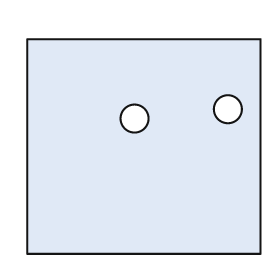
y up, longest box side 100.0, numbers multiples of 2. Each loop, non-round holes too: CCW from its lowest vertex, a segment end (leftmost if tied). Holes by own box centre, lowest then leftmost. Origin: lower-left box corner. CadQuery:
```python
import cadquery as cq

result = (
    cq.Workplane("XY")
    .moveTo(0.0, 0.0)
    .lineTo(100.0, 0.0)
    .lineTo(100.0, 92.0)
    .lineTo(0.0, 92.0)
    .close()
    .moveTo(46.0, 58.0)
    .circle(6.0)
    .moveTo(86.0, 62.0)
    .circle(6.0)
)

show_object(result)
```